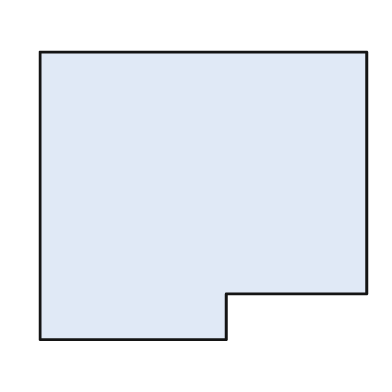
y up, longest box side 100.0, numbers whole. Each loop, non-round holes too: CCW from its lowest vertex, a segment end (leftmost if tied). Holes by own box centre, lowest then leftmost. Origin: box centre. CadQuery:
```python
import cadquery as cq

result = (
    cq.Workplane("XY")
    .moveTo(-50.0, -44.0)
    .lineTo(7.0, -44.0)
    .lineTo(7.0, -30.0)
    .lineTo(50.0, -30.0)
    .lineTo(50.0, 44.0)
    .lineTo(-50.0, 44.0)
    .close()
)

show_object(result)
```